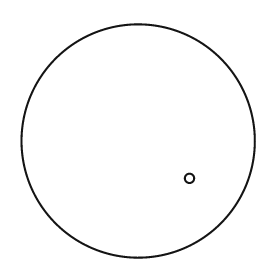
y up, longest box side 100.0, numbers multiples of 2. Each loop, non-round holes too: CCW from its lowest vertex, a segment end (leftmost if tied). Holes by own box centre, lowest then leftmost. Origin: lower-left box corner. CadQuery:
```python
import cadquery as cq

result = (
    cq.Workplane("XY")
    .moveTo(50.0, 50.0)
    .circle(50.0)
    .moveTo(72.0, 34.0)
    .circle(2.0)
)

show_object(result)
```